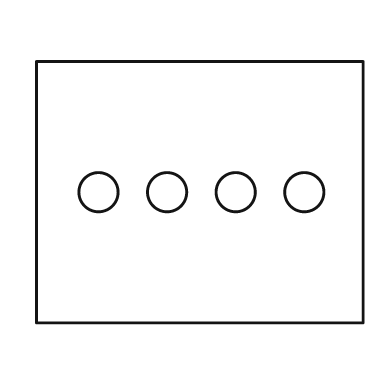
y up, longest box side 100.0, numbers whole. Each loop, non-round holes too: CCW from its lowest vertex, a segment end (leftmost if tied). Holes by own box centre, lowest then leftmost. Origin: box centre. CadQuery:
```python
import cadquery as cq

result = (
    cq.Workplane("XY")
    .moveTo(-50.0, -40.0)
    .lineTo(50.0, -40.0)
    .lineTo(50.0, 40.0)
    .lineTo(-50.0, 40.0)
    .close()
    .moveTo(-31.0, 0.0)
    .circle(6.0)
    .moveTo(-10.0, 0.0)
    .circle(6.0)
    .moveTo(11.0, 0.0)
    .circle(6.0)
    .moveTo(32.0, 0.0)
    .circle(6.0)
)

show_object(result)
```